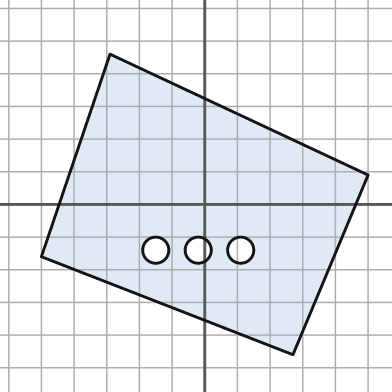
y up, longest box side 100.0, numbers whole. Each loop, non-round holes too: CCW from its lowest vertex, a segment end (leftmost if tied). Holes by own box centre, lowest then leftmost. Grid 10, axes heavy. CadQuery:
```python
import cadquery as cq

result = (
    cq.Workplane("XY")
    .moveTo(27.0, -46.0)
    .lineTo(50.0, 9.0)
    .lineTo(-29.0, 46.0)
    .lineTo(-50.0, -16.0)
    .close()
    .moveTo(-15.0, -14.0)
    .circle(4.0)
    .moveTo(-2.0, -14.0)
    .circle(4.0)
    .moveTo(11.0, -14.0)
    .circle(4.0)
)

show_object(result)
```